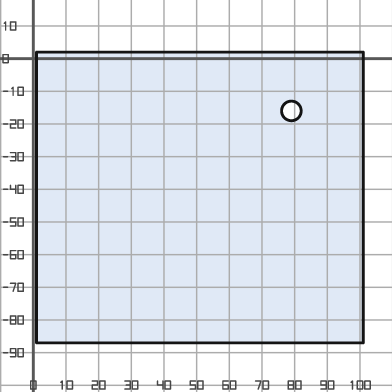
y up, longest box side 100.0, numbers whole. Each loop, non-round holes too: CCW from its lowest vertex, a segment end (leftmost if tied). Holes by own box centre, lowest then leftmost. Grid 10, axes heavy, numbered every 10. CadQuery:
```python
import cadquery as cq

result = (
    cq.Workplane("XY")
    .moveTo(1.0, -87.0)
    .lineTo(101.0, -87.0)
    .lineTo(101.0, 2.0)
    .lineTo(1.0, 2.0)
    .close()
    .moveTo(79.0, -16.0)
    .circle(3.0)
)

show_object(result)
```